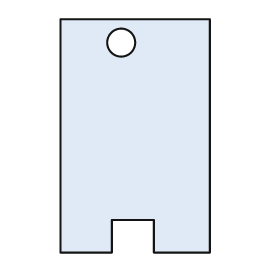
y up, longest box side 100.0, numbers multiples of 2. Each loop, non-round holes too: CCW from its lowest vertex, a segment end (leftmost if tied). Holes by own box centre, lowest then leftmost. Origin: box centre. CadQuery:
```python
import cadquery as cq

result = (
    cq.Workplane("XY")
    .moveTo(-32.0, -50.0)
    .lineTo(-10.0, -50.0)
    .lineTo(-10.0, -36.0)
    .lineTo(8.0, -36.0)
    .lineTo(8.0, -50.0)
    .lineTo(32.0, -50.0)
    .lineTo(32.0, 50.0)
    .lineTo(-32.0, 50.0)
    .close()
    .moveTo(-6.0, 40.0)
    .circle(6.0)
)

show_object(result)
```